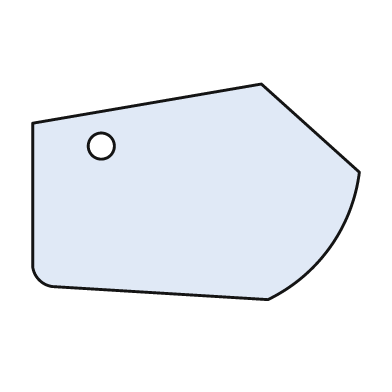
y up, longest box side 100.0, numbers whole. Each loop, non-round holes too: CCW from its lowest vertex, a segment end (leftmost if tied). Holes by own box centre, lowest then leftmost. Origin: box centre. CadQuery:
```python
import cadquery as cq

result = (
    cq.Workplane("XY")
    .moveTo(22.0, -33.0)
    .threePointArc((41.0, -17.0), (50.0, 6.0))
    .lineTo(20.0, 33.0)
    .lineTo(-50.0, 21.0)
    .lineTo(-50.0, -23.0)
    .threePointArc((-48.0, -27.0), (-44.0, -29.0))
    .close()
    .moveTo(-29.0, 14.0)
    .circle(4.0)
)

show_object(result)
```